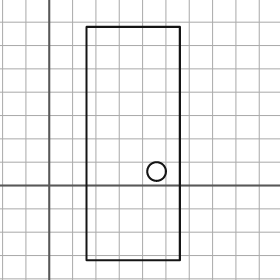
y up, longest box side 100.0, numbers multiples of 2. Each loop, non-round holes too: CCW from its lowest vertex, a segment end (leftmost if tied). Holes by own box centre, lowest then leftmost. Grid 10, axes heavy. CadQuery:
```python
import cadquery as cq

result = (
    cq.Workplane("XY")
    .moveTo(16.0, -32.0)
    .lineTo(56.0, -32.0)
    .lineTo(56.0, 68.0)
    .lineTo(16.0, 68.0)
    .close()
    .moveTo(46.0, 6.0)
    .circle(4.0)
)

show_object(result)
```